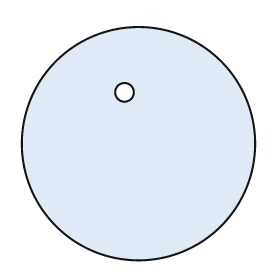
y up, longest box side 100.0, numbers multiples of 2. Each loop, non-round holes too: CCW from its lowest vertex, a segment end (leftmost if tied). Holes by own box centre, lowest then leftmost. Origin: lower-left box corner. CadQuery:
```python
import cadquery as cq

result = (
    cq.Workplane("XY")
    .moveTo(50.0, 50.0)
    .circle(50.0)
    .moveTo(44.0, 72.0)
    .circle(4.0)
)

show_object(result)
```